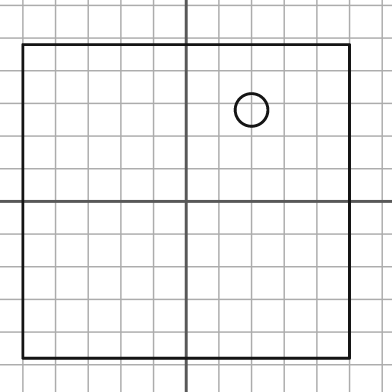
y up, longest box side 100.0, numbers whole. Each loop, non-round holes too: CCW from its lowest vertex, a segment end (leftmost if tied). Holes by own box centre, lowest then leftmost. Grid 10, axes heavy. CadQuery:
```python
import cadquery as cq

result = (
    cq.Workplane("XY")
    .moveTo(-50.0, -48.0)
    .lineTo(50.0, -48.0)
    .lineTo(50.0, 48.0)
    .lineTo(-50.0, 48.0)
    .close()
    .moveTo(20.0, 28.0)
    .circle(5.0)
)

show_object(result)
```